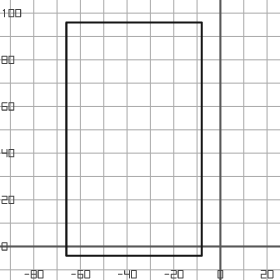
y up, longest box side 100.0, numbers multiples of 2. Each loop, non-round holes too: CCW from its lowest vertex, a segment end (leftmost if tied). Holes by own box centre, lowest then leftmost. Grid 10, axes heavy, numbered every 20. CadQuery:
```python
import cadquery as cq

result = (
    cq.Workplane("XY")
    .moveTo(-66.0, -4.0)
    .lineTo(-8.0, -4.0)
    .lineTo(-8.0, 96.0)
    .lineTo(-66.0, 96.0)
    .close()
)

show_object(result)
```